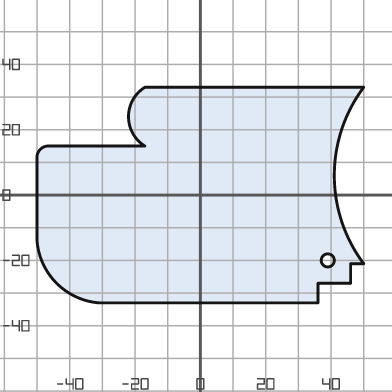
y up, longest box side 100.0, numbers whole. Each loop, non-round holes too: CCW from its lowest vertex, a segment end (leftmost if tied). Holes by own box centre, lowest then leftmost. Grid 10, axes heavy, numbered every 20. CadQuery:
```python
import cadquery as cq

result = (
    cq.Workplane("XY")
    .moveTo(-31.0, -33.0)
    .lineTo(36.0, -33.0)
    .lineTo(36.0, -27.0)
    .lineTo(46.0, -27.0)
    .lineTo(46.0, -21.0)
    .lineTo(50.0, -21.0)
    .threePointArc((41.0, 6.0), (50.0, 33.0))
    .lineTo(-17.0, 33.0)
    .threePointArc((-22.0, 24.0), (-17.0, 15.0))
    .lineTo(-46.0, 15.0)
    .threePointArc((-49.0, 14.0), (-50.0, 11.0))
    .lineTo(-50.0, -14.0)
    .threePointArc((-44.0, -27.0), (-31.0, -33.0))
    .close()
    .moveTo(39.0, -20.0)
    .circle(2.0)
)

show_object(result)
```